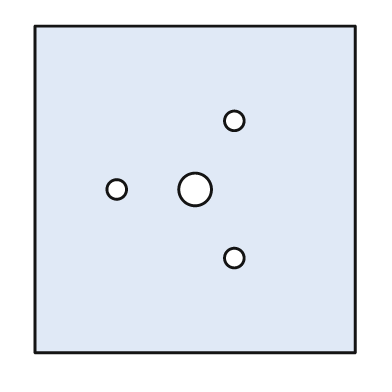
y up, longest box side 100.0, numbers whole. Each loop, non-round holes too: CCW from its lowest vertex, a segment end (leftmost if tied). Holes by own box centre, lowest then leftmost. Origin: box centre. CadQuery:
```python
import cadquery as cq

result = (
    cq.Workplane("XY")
    .moveTo(-49.0, -50.0)
    .lineTo(49.0, -50.0)
    .lineTo(49.0, 50.0)
    .lineTo(-49.0, 50.0)
    .close()
    .moveTo(12.0, -21.0)
    .circle(3.0)
    .moveTo(-24.0, 0.0)
    .circle(3.0)
    .moveTo(0.0, 0.0)
    .circle(5.0)
    .moveTo(12.0, 21.0)
    .circle(3.0)
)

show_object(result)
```